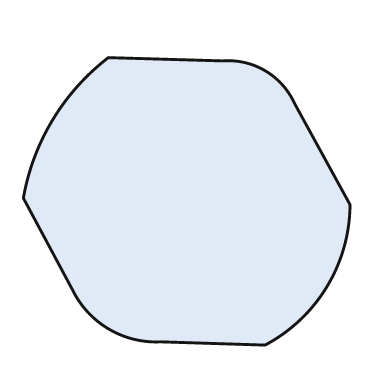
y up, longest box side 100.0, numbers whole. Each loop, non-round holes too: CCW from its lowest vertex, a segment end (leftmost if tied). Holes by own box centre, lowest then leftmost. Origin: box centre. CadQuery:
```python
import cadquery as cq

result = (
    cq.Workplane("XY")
    .moveTo(24.0, -44.0)
    .threePointArc((43.0, -26.0), (50.0, -1.0))
    .lineTo(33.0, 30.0)
    .threePointArc((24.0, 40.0), (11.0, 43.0))
    .lineTo(-24.0, 44.0)
    .threePointArc((-41.0, 25.0), (-50.0, 1.0))
    .lineTo(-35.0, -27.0)
    .threePointArc((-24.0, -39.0), (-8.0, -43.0))
    .close()
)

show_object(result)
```